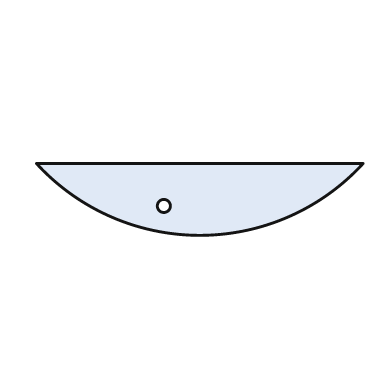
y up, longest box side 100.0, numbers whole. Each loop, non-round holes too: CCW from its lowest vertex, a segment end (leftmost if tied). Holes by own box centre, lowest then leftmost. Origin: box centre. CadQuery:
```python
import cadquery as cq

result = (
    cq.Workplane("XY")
    .moveTo(-50.0, 11.0)
    .threePointArc((0.0, -11.0), (50.0, 11.0))
    .close()
    .moveTo(-11.0, -2.0)
    .circle(2.0)
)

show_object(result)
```